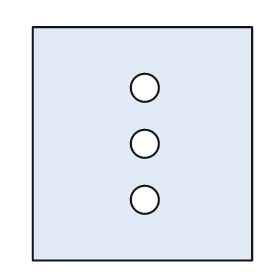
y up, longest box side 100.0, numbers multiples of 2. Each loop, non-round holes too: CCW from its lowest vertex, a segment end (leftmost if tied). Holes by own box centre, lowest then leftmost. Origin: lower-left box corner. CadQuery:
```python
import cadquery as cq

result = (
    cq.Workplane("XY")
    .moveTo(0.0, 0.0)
    .lineTo(94.0, 0.0)
    .lineTo(94.0, 100.0)
    .lineTo(0.0, 100.0)
    .close()
    .moveTo(48.0, 26.0)
    .circle(6.0)
    .moveTo(48.0, 50.0)
    .circle(6.0)
    .moveTo(48.0, 74.0)
    .circle(6.0)
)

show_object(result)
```